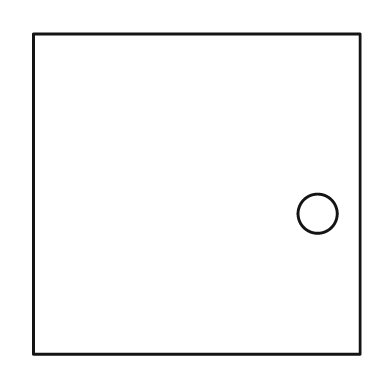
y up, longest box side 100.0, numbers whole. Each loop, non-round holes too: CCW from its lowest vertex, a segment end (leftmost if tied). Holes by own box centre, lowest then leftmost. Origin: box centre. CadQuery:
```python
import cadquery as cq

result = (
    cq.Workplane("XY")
    .moveTo(-50.0, -49.0)
    .lineTo(50.0, -49.0)
    .lineTo(50.0, 49.0)
    .lineTo(-50.0, 49.0)
    .close()
    .moveTo(37.0, -6.0)
    .circle(6.0)
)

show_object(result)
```